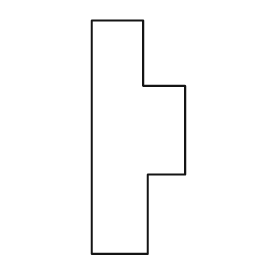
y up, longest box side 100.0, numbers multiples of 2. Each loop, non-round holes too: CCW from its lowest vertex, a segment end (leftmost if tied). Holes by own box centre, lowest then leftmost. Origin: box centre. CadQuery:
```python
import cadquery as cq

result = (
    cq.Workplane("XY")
    .moveTo(-20.0, -50.0)
    .lineTo(4.0, -50.0)
    .lineTo(4.0, -16.0)
    .lineTo(20.0, -16.0)
    .lineTo(20.0, 22.0)
    .lineTo(2.0, 22.0)
    .lineTo(2.0, 50.0)
    .lineTo(-20.0, 50.0)
    .close()
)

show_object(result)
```